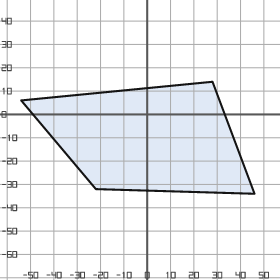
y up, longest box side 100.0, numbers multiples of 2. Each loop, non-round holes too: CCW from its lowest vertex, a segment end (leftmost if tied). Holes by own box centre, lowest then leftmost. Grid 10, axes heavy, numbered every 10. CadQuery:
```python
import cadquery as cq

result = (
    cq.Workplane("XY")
    .moveTo(46.0, -34.0)
    .lineTo(28.0, 14.0)
    .lineTo(-54.0, 6.0)
    .lineTo(-22.0, -32.0)
    .close()
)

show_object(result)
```